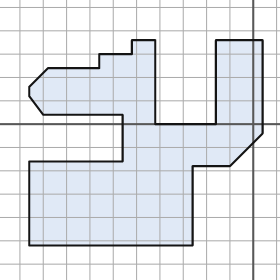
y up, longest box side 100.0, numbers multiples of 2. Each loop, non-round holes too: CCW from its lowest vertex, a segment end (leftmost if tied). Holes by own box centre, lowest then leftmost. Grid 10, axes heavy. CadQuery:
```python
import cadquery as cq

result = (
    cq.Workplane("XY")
    .moveTo(-96.0, -52.0)
    .lineTo(-26.0, -52.0)
    .lineTo(-26.0, -18.0)
    .lineTo(-10.0, -18.0)
    .lineTo(4.0, -4.0)
    .lineTo(4.0, 36.0)
    .lineTo(-16.0, 36.0)
    .lineTo(-16.0, 0.0)
    .lineTo(-42.0, 0.0)
    .lineTo(-42.0, 36.0)
    .lineTo(-52.0, 36.0)
    .lineTo(-52.0, 30.0)
    .lineTo(-66.0, 30.0)
    .lineTo(-66.0, 24.0)
    .lineTo(-88.0, 24.0)
    .lineTo(-96.0, 16.0)
    .lineTo(-96.0, 12.0)
    .lineTo(-90.0, 4.0)
    .lineTo(-56.0, 4.0)
    .lineTo(-56.0, -16.0)
    .lineTo(-96.0, -16.0)
    .close()
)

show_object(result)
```